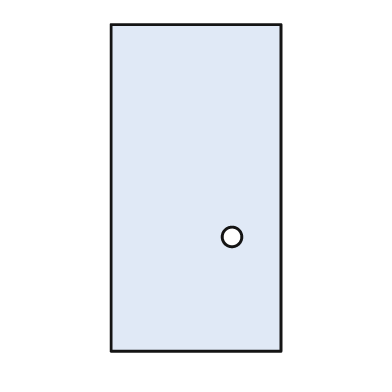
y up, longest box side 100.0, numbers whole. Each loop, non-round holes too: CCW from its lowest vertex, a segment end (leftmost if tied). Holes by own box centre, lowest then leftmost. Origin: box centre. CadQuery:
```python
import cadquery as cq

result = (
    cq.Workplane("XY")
    .moveTo(-26.0, -50.0)
    .lineTo(26.0, -50.0)
    .lineTo(26.0, 50.0)
    .lineTo(-26.0, 50.0)
    .close()
    .moveTo(11.0, -15.0)
    .circle(3.0)
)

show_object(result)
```